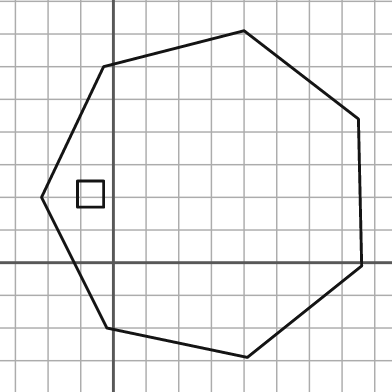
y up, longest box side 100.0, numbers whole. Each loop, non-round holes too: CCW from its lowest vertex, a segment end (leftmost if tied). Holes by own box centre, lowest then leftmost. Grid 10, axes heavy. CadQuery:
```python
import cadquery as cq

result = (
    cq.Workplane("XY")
    .moveTo(41.0, -29.0)
    .lineTo(76.0, -1.0)
    .lineTo(75.0, 44.0)
    .lineTo(40.0, 71.0)
    .lineTo(-3.0, 60.0)
    .lineTo(-22.0, 20.0)
    .lineTo(-2.0, -20.0)
    .close()
    .moveTo(-11.0, 17.0)
    .lineTo(-3.0, 17.0)
    .lineTo(-3.0, 25.0)
    .lineTo(-11.0, 25.0)
    .close()
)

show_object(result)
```